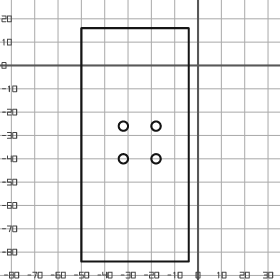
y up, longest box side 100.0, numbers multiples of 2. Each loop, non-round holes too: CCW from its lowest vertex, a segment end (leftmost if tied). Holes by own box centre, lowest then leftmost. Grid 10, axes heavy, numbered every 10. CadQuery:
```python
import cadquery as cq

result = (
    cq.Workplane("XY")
    .moveTo(-50.0, -84.0)
    .lineTo(-4.0, -84.0)
    .lineTo(-4.0, 16.0)
    .lineTo(-50.0, 16.0)
    .close()
    .moveTo(-32.0, -40.0)
    .circle(2.0)
    .moveTo(-18.0, -40.0)
    .circle(2.0)
    .moveTo(-32.0, -26.0)
    .circle(2.0)
    .moveTo(-18.0, -26.0)
    .circle(2.0)
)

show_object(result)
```